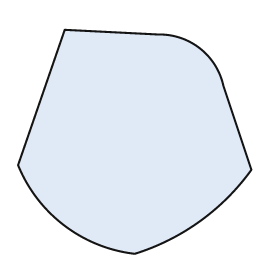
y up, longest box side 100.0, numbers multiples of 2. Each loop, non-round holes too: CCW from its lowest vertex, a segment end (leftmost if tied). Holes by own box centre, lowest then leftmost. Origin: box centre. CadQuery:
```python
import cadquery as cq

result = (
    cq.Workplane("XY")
    .moveTo(0.0, -48.0)
    .threePointArc((28.0, -34.0), (50.0, -12.0))
    .lineTo(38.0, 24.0)
    .threePointArc((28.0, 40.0), (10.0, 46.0))
    .lineTo(-30.0, 48.0)
    .lineTo(-50.0, -10.0)
    .threePointArc((-30.0, -36.0), (0.0, -48.0))
    .close()
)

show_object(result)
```